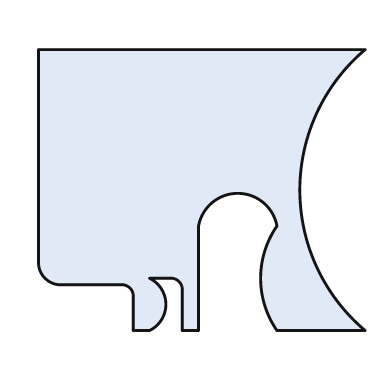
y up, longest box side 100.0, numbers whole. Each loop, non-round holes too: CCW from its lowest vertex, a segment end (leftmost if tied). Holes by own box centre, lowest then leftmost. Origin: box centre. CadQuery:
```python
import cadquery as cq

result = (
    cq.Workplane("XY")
    .moveTo(-21.0, -43.0)
    .lineTo(-16.0, -43.0)
    .threePointArc((-11.0, -35.0), (-16.0, -27.0))
    .lineTo(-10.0, -27.0)
    .threePointArc((-7.0, -28.0), (-6.0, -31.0))
    .lineTo(-6.0, -43.0)
    .lineTo(-1.0, -43.0)
    .lineTo(-1.0, -11.0)
    .threePointArc((11.0, -1.0), (23.0, -11.0))
    .threePointArc((18.0, -27.0), (23.0, -43.0))
    .lineTo(50.0, -43.0)
    .threePointArc((30.0, 0.0), (50.0, 43.0))
    .lineTo(-50.0, 43.0)
    .lineTo(-50.0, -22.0)
    .threePointArc((-48.0, -27.0), (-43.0, -29.0))
    .lineTo(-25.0, -29.0)
    .threePointArc((-22.0, -30.0), (-21.0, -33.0))
    .close()
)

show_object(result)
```